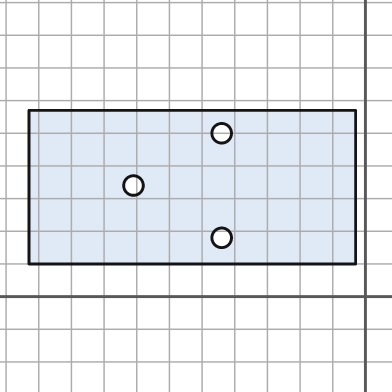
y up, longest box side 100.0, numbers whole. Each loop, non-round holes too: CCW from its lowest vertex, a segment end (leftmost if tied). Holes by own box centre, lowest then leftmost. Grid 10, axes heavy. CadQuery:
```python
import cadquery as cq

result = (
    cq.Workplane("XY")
    .moveTo(-103.0, 10.0)
    .lineTo(-3.0, 10.0)
    .lineTo(-3.0, 57.0)
    .lineTo(-103.0, 57.0)
    .close()
    .moveTo(-44.0, 18.0)
    .circle(3.0)
    .moveTo(-71.0, 34.0)
    .circle(3.0)
    .moveTo(-44.0, 50.0)
    .circle(3.0)
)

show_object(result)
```